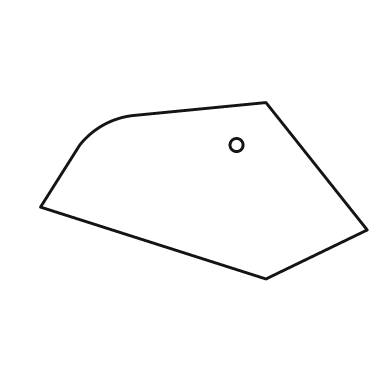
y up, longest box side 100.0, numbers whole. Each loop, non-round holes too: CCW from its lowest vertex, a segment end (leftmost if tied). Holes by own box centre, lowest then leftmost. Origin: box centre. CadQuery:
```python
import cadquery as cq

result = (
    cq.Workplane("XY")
    .moveTo(19.0, -27.0)
    .lineTo(50.0, -12.0)
    .lineTo(19.0, 27.0)
    .lineTo(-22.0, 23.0)
    .threePointArc((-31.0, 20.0), (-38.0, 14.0))
    .lineTo(-50.0, -5.0)
    .close()
    .moveTo(10.0, 14.0)
    .circle(2.0)
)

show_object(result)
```